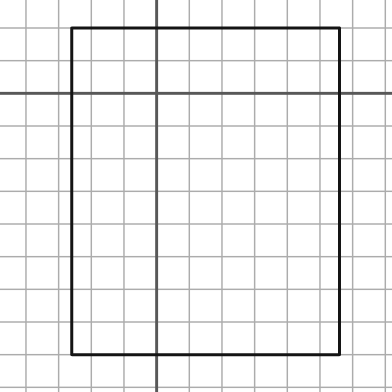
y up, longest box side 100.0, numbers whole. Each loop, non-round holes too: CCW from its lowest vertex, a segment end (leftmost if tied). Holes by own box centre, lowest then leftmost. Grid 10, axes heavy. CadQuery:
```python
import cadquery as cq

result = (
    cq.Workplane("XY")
    .moveTo(-26.0, -80.0)
    .lineTo(56.0, -80.0)
    .lineTo(56.0, 20.0)
    .lineTo(-26.0, 20.0)
    .close()
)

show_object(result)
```